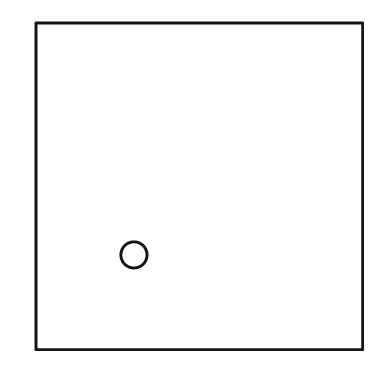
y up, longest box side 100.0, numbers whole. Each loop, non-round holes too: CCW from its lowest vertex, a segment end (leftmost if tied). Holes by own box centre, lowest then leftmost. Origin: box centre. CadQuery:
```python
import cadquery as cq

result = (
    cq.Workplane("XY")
    .moveTo(-50.0, -50.0)
    .lineTo(50.0, -50.0)
    .lineTo(50.0, 50.0)
    .lineTo(-50.0, 50.0)
    .close()
    .moveTo(-20.0, -21.0)
    .circle(4.0)
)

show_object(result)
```